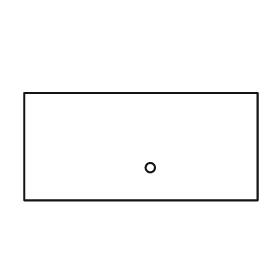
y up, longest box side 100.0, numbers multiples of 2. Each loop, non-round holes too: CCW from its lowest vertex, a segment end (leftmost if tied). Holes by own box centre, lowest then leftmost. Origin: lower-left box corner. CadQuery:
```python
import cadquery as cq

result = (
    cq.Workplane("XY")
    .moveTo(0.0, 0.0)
    .lineTo(100.0, 0.0)
    .lineTo(100.0, 46.0)
    .lineTo(0.0, 46.0)
    .close()
    .moveTo(54.0, 14.0)
    .circle(2.0)
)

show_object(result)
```